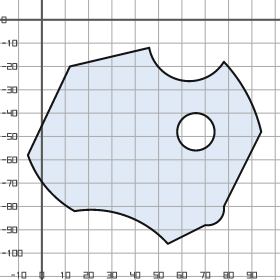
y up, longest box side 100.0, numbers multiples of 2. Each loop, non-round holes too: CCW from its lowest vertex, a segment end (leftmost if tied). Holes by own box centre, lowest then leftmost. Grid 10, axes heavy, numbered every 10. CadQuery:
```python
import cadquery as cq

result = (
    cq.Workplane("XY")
    .moveTo(54.0, -96.0)
    .lineTo(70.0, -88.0)
    .threePointArc((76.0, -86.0), (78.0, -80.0))
    .lineTo(94.0, -48.0)
    .threePointArc((88.0, -32.0), (78.0, -18.0))
    .threePointArc((60.0, -26.0), (46.0, -12.0))
    .lineTo(12.0, -20.0)
    .lineTo(-6.0, -58.0)
    .threePointArc((2.0, -72.0), (14.0, -82.0))
    .threePointArc((36.0, -84.0), (54.0, -96.0))
    .close()
    .moveTo(66.0, -48.0)
    .circle(8.0)
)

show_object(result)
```